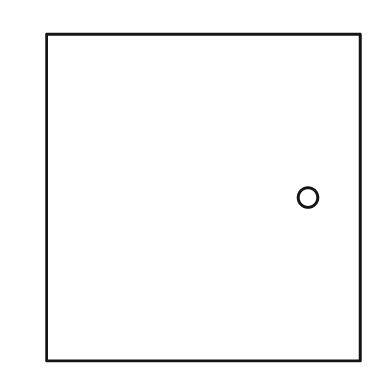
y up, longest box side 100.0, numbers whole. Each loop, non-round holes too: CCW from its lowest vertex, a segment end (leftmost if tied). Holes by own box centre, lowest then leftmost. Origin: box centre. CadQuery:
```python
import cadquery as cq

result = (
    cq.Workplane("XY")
    .moveTo(-48.0, -50.0)
    .lineTo(48.0, -50.0)
    .lineTo(48.0, 50.0)
    .lineTo(-48.0, 50.0)
    .close()
    .moveTo(32.0, 0.0)
    .circle(3.0)
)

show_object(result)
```